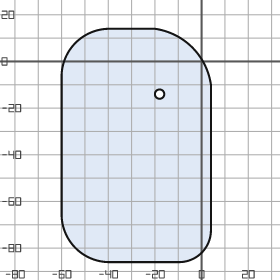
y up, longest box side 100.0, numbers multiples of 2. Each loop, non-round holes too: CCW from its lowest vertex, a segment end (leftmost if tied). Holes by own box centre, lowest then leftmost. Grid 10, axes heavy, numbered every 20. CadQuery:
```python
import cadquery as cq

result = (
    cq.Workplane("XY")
    .moveTo(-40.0, -86.0)
    .lineTo(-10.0, -86.0)
    .threePointArc((0.0, -82.0), (4.0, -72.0))
    .lineTo(4.0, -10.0)
    .threePointArc((-4.0, 6.0), (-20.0, 14.0))
    .lineTo(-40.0, 14.0)
    .threePointArc((-54.0, 8.0), (-60.0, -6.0))
    .lineTo(-60.0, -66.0)
    .threePointArc((-54.0, -80.0), (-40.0, -86.0))
    .close()
    .moveTo(-18.0, -14.0)
    .circle(2.0)
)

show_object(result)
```